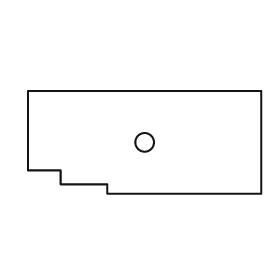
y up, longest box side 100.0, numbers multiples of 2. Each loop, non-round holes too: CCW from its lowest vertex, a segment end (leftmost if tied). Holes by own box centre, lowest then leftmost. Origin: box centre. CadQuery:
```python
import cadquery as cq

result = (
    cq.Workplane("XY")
    .moveTo(-16.0, -22.0)
    .lineTo(50.0, -22.0)
    .lineTo(50.0, 22.0)
    .lineTo(-50.0, 22.0)
    .lineTo(-50.0, -12.0)
    .lineTo(-36.0, -12.0)
    .lineTo(-36.0, -18.0)
    .lineTo(-16.0, -18.0)
    .close()
    .moveTo(0.0, 0.0)
    .circle(4.0)
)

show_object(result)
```